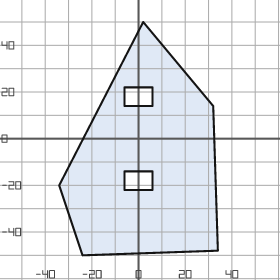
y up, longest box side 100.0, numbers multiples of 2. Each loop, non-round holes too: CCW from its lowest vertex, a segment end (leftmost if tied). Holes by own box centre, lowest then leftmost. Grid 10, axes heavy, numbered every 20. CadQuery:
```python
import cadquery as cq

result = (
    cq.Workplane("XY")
    .moveTo(-24.0, -50.0)
    .lineTo(34.0, -48.0)
    .lineTo(32.0, 14.0)
    .lineTo(2.0, 50.0)
    .lineTo(-34.0, -20.0)
    .close()
    .moveTo(-6.0, -22.0)
    .lineTo(6.0, -22.0)
    .lineTo(6.0, -14.0)
    .lineTo(-6.0, -14.0)
    .close()
    .moveTo(-6.0, 14.0)
    .lineTo(6.0, 14.0)
    .lineTo(6.0, 22.0)
    .lineTo(-6.0, 22.0)
    .close()
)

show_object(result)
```